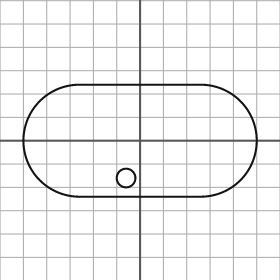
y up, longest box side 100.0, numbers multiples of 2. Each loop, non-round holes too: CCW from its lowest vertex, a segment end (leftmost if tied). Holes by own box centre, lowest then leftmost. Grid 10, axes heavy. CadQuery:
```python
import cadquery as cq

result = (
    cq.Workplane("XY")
    .moveTo(-26.0, -24.0)
    .lineTo(26.0, -24.0)
    .threePointArc((50.0, 0.0), (26.0, 24.0))
    .lineTo(-26.0, 24.0)
    .threePointArc((-50.0, 0.0), (-26.0, -24.0))
    .close()
    .moveTo(-6.0, -16.0)
    .circle(4.0)
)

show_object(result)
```